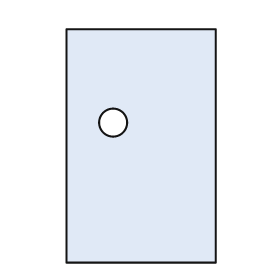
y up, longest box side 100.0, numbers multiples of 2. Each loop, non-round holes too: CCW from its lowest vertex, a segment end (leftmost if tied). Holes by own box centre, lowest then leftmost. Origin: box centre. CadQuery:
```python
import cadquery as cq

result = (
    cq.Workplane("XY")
    .moveTo(-32.0, -50.0)
    .lineTo(32.0, -50.0)
    .lineTo(32.0, 50.0)
    .lineTo(-32.0, 50.0)
    .close()
    .moveTo(-12.0, 10.0)
    .circle(6.0)
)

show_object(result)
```